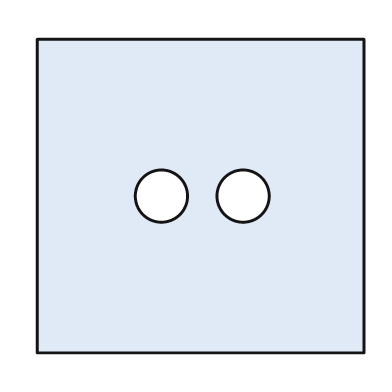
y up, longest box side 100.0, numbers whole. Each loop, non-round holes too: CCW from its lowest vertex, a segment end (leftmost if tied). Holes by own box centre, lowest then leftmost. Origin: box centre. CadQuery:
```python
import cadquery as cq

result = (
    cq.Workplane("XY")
    .moveTo(-50.0, -48.0)
    .lineTo(50.0, -48.0)
    .lineTo(50.0, 48.0)
    .lineTo(-50.0, 48.0)
    .close()
    .moveTo(-12.0, 0.0)
    .circle(8.0)
    .moveTo(13.0, 0.0)
    .circle(8.0)
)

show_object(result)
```